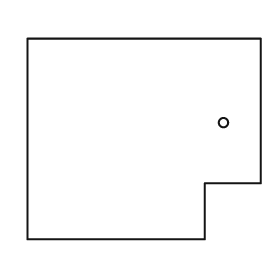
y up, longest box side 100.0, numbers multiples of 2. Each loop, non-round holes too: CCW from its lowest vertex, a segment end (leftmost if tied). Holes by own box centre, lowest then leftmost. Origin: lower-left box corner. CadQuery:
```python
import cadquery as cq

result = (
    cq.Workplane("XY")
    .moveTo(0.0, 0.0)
    .lineTo(76.0, 0.0)
    .lineTo(76.0, 24.0)
    .lineTo(100.0, 24.0)
    .lineTo(100.0, 86.0)
    .lineTo(0.0, 86.0)
    .close()
    .moveTo(84.0, 50.0)
    .circle(2.0)
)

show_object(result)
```